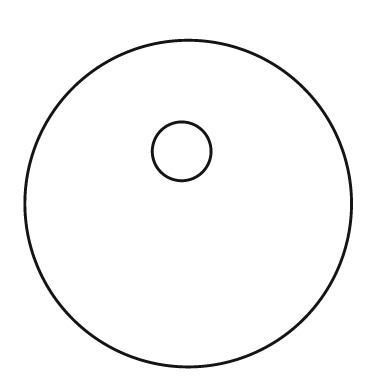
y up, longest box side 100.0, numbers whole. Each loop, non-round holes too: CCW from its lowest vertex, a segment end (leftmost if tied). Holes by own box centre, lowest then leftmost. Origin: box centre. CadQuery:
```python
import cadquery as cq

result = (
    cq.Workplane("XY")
    .moveTo(0.0, 0.0)
    .circle(50.0)
    .moveTo(-2.0, 16.0)
    .circle(9.0)
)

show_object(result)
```